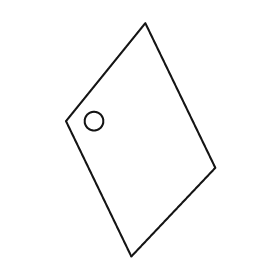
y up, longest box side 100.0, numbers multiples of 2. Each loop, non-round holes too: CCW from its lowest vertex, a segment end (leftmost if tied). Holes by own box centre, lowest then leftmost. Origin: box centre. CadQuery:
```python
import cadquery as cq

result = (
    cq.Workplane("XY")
    .moveTo(-4.0, -50.0)
    .lineTo(32.0, -12.0)
    .lineTo(2.0, 50.0)
    .lineTo(-32.0, 8.0)
    .close()
    .moveTo(-20.0, 8.0)
    .circle(4.0)
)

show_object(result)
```